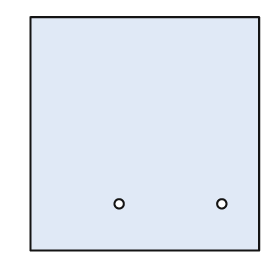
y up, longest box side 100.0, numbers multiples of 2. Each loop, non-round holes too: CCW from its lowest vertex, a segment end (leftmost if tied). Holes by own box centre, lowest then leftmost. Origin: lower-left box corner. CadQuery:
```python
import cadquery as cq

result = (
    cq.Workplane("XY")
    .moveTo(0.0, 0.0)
    .lineTo(98.0, 0.0)
    .lineTo(98.0, 100.0)
    .lineTo(0.0, 100.0)
    .close()
    .moveTo(38.0, 20.0)
    .circle(2.0)
    .moveTo(82.0, 20.0)
    .circle(2.0)
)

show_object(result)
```